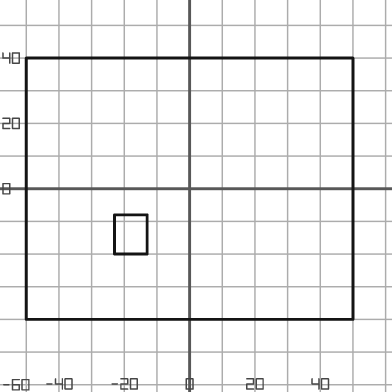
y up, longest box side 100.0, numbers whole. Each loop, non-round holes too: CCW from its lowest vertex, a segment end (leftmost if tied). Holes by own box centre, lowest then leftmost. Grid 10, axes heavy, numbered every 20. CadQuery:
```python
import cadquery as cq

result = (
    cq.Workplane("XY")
    .moveTo(-50.0, -40.0)
    .lineTo(50.0, -40.0)
    .lineTo(50.0, 40.0)
    .lineTo(-50.0, 40.0)
    .close()
    .moveTo(-23.0, -20.0)
    .lineTo(-13.0, -20.0)
    .lineTo(-13.0, -8.0)
    .lineTo(-23.0, -8.0)
    .close()
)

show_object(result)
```